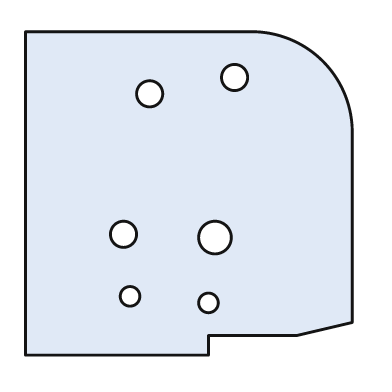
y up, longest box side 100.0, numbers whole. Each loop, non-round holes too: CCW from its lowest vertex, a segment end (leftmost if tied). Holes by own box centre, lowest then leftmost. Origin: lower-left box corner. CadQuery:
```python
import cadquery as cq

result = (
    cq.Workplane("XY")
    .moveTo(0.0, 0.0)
    .lineTo(56.0, 0.0)
    .lineTo(56.0, 6.0)
    .lineTo(83.0, 6.0)
    .lineTo(100.0, 10.0)
    .lineTo(100.0, 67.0)
    .threePointArc((91.0, 90.0), (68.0, 99.0))
    .lineTo(0.0, 99.0)
    .close()
    .moveTo(56.0, 16.0)
    .circle(3.0)
    .moveTo(32.0, 18.0)
    .circle(3.0)
    .moveTo(58.0, 36.0)
    .circle(5.0)
    .moveTo(30.0, 37.0)
    .circle(4.0)
    .moveTo(38.0, 80.0)
    .circle(4.0)
    .moveTo(64.0, 85.0)
    .circle(4.0)
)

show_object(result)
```